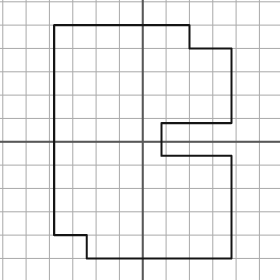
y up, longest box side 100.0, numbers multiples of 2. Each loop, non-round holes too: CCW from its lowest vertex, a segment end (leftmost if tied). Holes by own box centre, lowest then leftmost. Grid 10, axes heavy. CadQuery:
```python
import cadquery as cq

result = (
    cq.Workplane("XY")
    .moveTo(-24.0, -50.0)
    .lineTo(38.0, -50.0)
    .lineTo(38.0, -6.0)
    .lineTo(8.0, -6.0)
    .lineTo(8.0, 8.0)
    .lineTo(38.0, 8.0)
    .lineTo(38.0, 40.0)
    .lineTo(20.0, 40.0)
    .lineTo(20.0, 50.0)
    .lineTo(-38.0, 50.0)
    .lineTo(-38.0, -40.0)
    .lineTo(-24.0, -40.0)
    .close()
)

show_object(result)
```